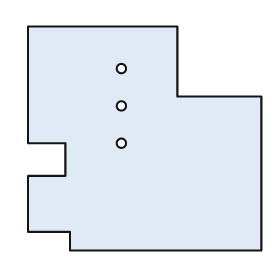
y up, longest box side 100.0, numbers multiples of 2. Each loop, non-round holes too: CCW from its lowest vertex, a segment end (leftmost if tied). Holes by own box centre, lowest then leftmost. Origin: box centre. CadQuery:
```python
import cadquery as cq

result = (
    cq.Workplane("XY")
    .moveTo(-32.0, -48.0)
    .lineTo(50.0, -48.0)
    .lineTo(50.0, 18.0)
    .lineTo(14.0, 18.0)
    .lineTo(14.0, 48.0)
    .lineTo(-50.0, 48.0)
    .lineTo(-50.0, -2.0)
    .lineTo(-34.0, -2.0)
    .lineTo(-34.0, -16.0)
    .lineTo(-50.0, -16.0)
    .lineTo(-50.0, -40.0)
    .lineTo(-32.0, -40.0)
    .close()
    .moveTo(-10.0, -2.0)
    .circle(2.0)
    .moveTo(-10.0, 14.0)
    .circle(2.0)
    .moveTo(-10.0, 30.0)
    .circle(2.0)
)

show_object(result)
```